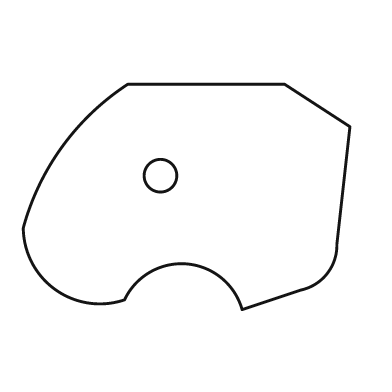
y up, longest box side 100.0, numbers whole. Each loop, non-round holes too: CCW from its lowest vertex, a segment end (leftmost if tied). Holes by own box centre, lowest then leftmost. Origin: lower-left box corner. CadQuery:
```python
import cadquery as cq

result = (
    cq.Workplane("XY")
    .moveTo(67.0, 0.0)
    .lineTo(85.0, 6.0)
    .threePointArc((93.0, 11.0), (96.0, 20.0))
    .lineTo(100.0, 56.0)
    .lineTo(80.0, 69.0)
    .lineTo(32.0, 69.0)
    .threePointArc((12.0, 50.0), (0.0, 25.0))
    .threePointArc((10.0, 6.0), (31.0, 3.0))
    .threePointArc((50.0, 14.0), (67.0, 0.0))
    .close()
    .moveTo(42.0, 41.0)
    .circle(5.0)
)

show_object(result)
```